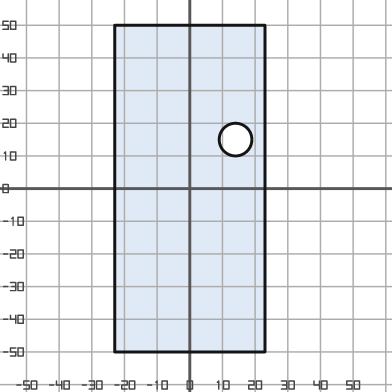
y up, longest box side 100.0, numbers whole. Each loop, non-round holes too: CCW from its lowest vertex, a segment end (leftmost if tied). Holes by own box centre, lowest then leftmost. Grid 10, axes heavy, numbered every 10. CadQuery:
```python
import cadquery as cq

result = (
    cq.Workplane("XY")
    .moveTo(-23.0, -50.0)
    .lineTo(23.0, -50.0)
    .lineTo(23.0, 50.0)
    .lineTo(-23.0, 50.0)
    .close()
    .moveTo(14.0, 15.0)
    .circle(5.0)
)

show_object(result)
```